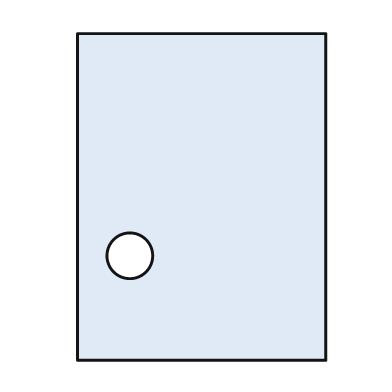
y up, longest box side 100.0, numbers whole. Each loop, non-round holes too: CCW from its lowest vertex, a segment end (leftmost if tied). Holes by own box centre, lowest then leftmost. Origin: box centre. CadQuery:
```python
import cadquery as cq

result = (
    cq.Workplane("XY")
    .moveTo(-38.0, -50.0)
    .lineTo(38.0, -50.0)
    .lineTo(38.0, 50.0)
    .lineTo(-38.0, 50.0)
    .close()
    .moveTo(-22.0, -18.0)
    .circle(7.0)
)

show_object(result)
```